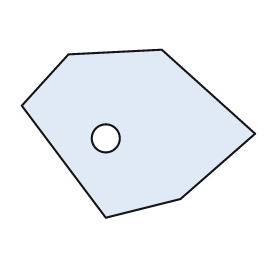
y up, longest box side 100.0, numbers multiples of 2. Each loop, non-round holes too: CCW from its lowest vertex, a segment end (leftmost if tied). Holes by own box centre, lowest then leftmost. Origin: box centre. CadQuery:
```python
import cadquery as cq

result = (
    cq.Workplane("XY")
    .moveTo(-14.0, -36.0)
    .lineTo(18.0, -28.0)
    .lineTo(50.0, 0.0)
    .lineTo(10.0, 36.0)
    .lineTo(-30.0, 34.0)
    .lineTo(-50.0, 12.0)
    .close()
    .moveTo(-14.0, -2.0)
    .circle(6.0)
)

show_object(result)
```